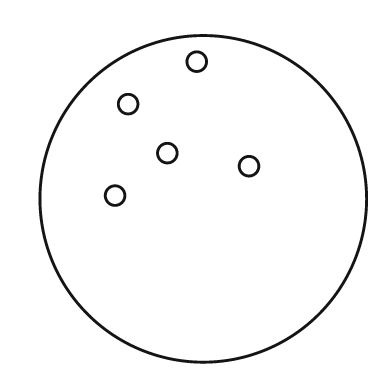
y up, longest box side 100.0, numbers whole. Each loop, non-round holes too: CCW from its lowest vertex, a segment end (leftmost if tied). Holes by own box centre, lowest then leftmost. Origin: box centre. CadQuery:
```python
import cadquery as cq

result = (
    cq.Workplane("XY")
    .moveTo(0.0, 0.0)
    .circle(50.0)
    .moveTo(-27.0, 1.0)
    .circle(3.0)
    .moveTo(14.0, 10.0)
    .circle(3.0)
    .moveTo(-11.0, 14.0)
    .circle(3.0)
    .moveTo(-23.0, 29.0)
    .circle(3.0)
    .moveTo(-2.0, 42.0)
    .circle(3.0)
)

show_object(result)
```